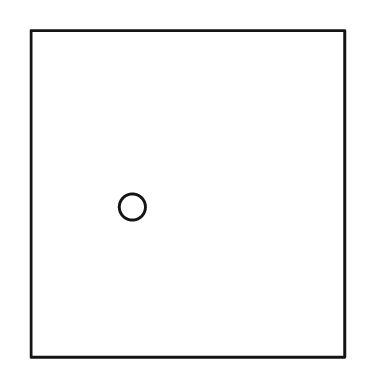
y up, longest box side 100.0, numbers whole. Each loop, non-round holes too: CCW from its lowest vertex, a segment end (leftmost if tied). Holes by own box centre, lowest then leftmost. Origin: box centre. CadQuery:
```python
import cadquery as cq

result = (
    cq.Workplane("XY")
    .moveTo(-48.0, -50.0)
    .lineTo(48.0, -50.0)
    .lineTo(48.0, 50.0)
    .lineTo(-48.0, 50.0)
    .close()
    .moveTo(-17.0, -4.0)
    .circle(4.0)
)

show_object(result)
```